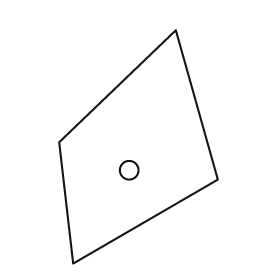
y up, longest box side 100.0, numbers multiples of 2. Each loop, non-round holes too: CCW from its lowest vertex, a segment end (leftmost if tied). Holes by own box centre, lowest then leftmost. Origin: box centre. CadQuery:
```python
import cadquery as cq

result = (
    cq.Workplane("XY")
    .moveTo(-28.0, -50.0)
    .lineTo(34.0, -14.0)
    .lineTo(16.0, 50.0)
    .lineTo(-34.0, 2.0)
    .close()
    .moveTo(-4.0, -10.0)
    .circle(4.0)
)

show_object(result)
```